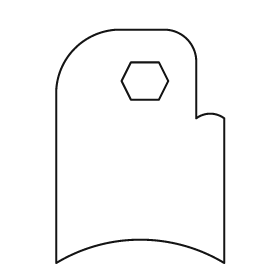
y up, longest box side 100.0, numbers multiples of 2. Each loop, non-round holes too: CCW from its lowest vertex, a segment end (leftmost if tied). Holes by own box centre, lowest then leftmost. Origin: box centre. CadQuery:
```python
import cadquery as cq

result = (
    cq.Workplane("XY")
    .moveTo(-36.0, -50.0)
    .threePointArc((0.0, -40.0), (36.0, -50.0))
    .lineTo(36.0, 12.0)
    .threePointArc((30.0, 14.0), (24.0, 12.0))
    .lineTo(24.0, 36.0)
    .threePointArc((20.0, 46.0), (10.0, 50.0))
    .lineTo(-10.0, 50.0)
    .threePointArc((-28.0, 42.0), (-36.0, 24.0))
    .close()
    .moveTo(-4.0, 20.0)
    .lineTo(8.0, 20.0)
    .lineTo(12.0, 28.0)
    .lineTo(8.0, 36.0)
    .lineTo(-4.0, 36.0)
    .lineTo(-8.0, 28.0)
    .close()
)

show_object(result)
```